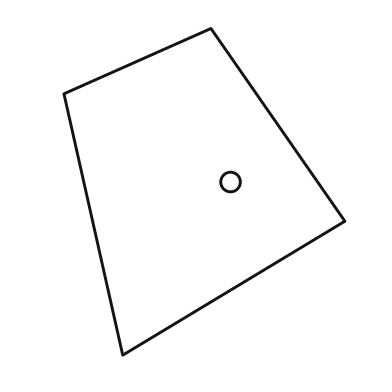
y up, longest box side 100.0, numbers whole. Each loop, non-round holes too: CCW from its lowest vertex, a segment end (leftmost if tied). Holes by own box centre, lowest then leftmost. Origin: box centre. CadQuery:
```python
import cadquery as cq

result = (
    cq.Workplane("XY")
    .moveTo(-25.0, -50.0)
    .lineTo(43.0, -9.0)
    .lineTo(2.0, 50.0)
    .lineTo(-43.0, 30.0)
    .close()
    .moveTo(8.0, 3.0)
    .circle(3.0)
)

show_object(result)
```